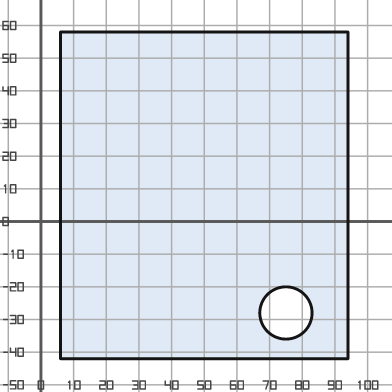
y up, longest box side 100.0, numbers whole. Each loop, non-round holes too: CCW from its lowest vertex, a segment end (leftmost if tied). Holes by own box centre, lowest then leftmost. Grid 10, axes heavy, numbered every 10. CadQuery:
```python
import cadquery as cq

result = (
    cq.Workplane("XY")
    .moveTo(6.0, -42.0)
    .lineTo(94.0, -42.0)
    .lineTo(94.0, 58.0)
    .lineTo(6.0, 58.0)
    .close()
    .moveTo(75.0, -28.0)
    .circle(8.0)
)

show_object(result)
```